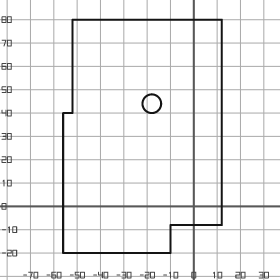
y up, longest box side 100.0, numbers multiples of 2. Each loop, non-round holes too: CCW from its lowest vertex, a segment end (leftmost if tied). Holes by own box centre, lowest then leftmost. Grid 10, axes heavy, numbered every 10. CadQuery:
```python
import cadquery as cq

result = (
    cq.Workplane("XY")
    .moveTo(-56.0, -20.0)
    .lineTo(-10.0, -20.0)
    .lineTo(-10.0, -8.0)
    .lineTo(12.0, -8.0)
    .lineTo(12.0, 80.0)
    .lineTo(-52.0, 80.0)
    .lineTo(-52.0, 40.0)
    .lineTo(-56.0, 40.0)
    .close()
    .moveTo(-18.0, 44.0)
    .circle(4.0)
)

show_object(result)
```